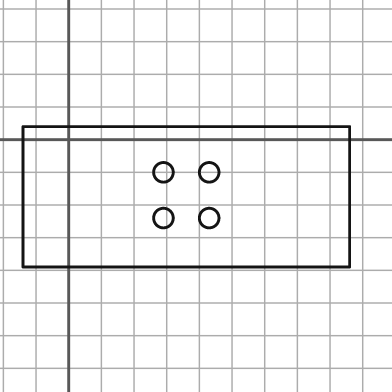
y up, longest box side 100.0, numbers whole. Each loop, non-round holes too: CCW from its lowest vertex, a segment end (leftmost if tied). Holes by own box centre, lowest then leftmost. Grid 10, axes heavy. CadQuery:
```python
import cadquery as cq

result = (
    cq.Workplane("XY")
    .moveTo(-14.0, -39.0)
    .lineTo(86.0, -39.0)
    .lineTo(86.0, 4.0)
    .lineTo(-14.0, 4.0)
    .close()
    .moveTo(29.0, -24.0)
    .circle(3.0)
    .moveTo(43.0, -24.0)
    .circle(3.0)
    .moveTo(29.0, -10.0)
    .circle(3.0)
    .moveTo(43.0, -10.0)
    .circle(3.0)
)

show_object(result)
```